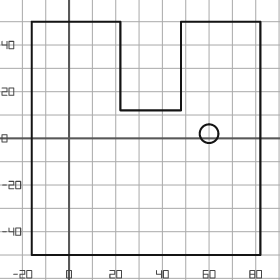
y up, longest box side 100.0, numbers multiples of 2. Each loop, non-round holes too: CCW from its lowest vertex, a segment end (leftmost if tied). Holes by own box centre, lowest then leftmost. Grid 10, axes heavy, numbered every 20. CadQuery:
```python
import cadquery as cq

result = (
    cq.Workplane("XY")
    .moveTo(-16.0, -50.0)
    .lineTo(82.0, -50.0)
    .lineTo(82.0, 50.0)
    .lineTo(48.0, 50.0)
    .lineTo(48.0, 12.0)
    .lineTo(22.0, 12.0)
    .lineTo(22.0, 50.0)
    .lineTo(-16.0, 50.0)
    .close()
    .moveTo(60.0, 2.0)
    .circle(4.0)
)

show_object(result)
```